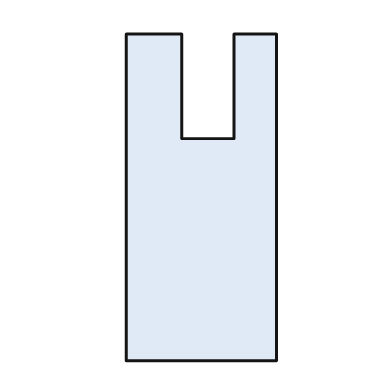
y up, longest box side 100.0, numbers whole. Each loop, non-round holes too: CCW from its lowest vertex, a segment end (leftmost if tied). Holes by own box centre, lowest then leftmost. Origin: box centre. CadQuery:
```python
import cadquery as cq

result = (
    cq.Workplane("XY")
    .moveTo(-23.0, -50.0)
    .lineTo(23.0, -50.0)
    .lineTo(23.0, 50.0)
    .lineTo(10.0, 50.0)
    .lineTo(10.0, 18.0)
    .lineTo(-6.0, 18.0)
    .lineTo(-6.0, 50.0)
    .lineTo(-23.0, 50.0)
    .close()
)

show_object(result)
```